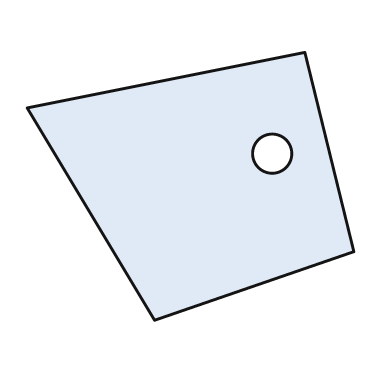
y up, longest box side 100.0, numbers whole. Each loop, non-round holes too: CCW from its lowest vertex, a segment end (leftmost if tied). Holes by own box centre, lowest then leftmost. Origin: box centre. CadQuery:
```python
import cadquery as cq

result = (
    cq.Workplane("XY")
    .moveTo(-11.0, -41.0)
    .lineTo(50.0, -20.0)
    .lineTo(35.0, 41.0)
    .lineTo(-50.0, 24.0)
    .close()
    .moveTo(25.0, 10.0)
    .circle(6.0)
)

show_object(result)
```